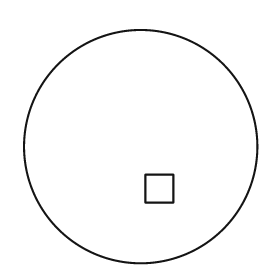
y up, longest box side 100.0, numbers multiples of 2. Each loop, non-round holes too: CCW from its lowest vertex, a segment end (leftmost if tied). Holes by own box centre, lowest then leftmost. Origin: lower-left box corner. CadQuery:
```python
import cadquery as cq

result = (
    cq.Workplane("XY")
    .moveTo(50.0, 50.0)
    .circle(50.0)
    .moveTo(52.0, 26.0)
    .lineTo(64.0, 26.0)
    .lineTo(64.0, 38.0)
    .lineTo(52.0, 38.0)
    .close()
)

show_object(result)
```